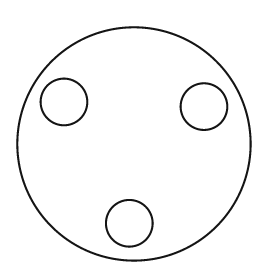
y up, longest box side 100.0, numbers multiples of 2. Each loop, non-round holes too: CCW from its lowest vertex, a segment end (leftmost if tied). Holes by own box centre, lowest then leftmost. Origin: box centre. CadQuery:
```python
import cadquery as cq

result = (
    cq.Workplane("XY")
    .moveTo(0.0, 0.0)
    .circle(50.0)
    .moveTo(-2.0, -34.0)
    .circle(10.0)
    .moveTo(30.0, 16.0)
    .circle(10.0)
    .moveTo(-30.0, 18.0)
    .circle(10.0)
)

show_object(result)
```